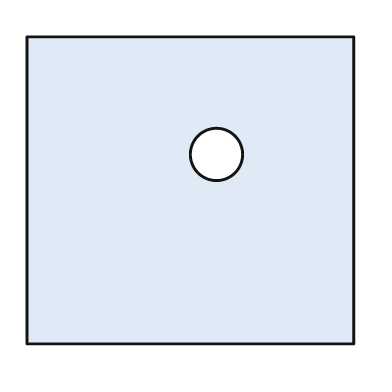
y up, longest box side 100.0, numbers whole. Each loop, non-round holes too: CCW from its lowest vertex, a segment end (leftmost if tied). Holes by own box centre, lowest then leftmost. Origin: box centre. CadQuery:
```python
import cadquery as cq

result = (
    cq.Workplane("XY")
    .moveTo(-50.0, -47.0)
    .lineTo(50.0, -47.0)
    .lineTo(50.0, 47.0)
    .lineTo(-50.0, 47.0)
    .close()
    .moveTo(8.0, 11.0)
    .circle(8.0)
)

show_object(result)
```